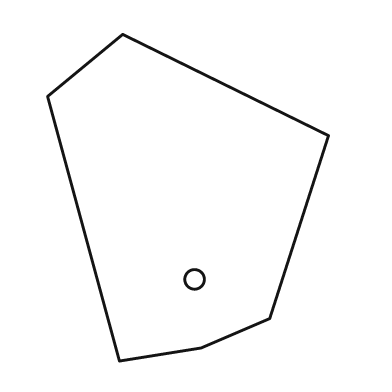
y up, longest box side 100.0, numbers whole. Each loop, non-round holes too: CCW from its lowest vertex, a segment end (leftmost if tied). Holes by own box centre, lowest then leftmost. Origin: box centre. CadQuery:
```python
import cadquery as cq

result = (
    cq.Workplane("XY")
    .moveTo(-21.0, -50.0)
    .lineTo(4.0, -46.0)
    .lineTo(25.0, -37.0)
    .lineTo(43.0, 19.0)
    .lineTo(-20.0, 50.0)
    .lineTo(-43.0, 31.0)
    .close()
    .moveTo(2.0, -25.0)
    .circle(3.0)
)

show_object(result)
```